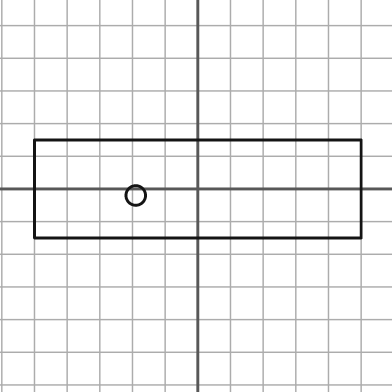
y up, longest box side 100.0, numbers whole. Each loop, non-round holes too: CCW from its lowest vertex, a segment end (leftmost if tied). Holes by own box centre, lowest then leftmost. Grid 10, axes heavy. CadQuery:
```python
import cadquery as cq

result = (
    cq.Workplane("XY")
    .moveTo(-50.0, -15.0)
    .lineTo(50.0, -15.0)
    .lineTo(50.0, 15.0)
    .lineTo(-50.0, 15.0)
    .close()
    .moveTo(-19.0, -2.0)
    .circle(3.0)
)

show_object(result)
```